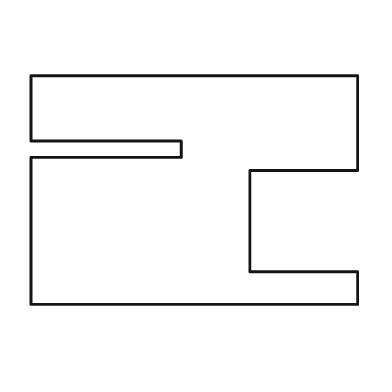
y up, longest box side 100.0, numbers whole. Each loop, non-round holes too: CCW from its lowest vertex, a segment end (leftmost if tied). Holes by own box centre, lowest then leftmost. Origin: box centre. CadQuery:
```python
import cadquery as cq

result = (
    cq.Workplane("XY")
    .moveTo(-50.0, -35.0)
    .lineTo(50.0, -35.0)
    .lineTo(50.0, -25.0)
    .lineTo(17.0, -25.0)
    .lineTo(17.0, 6.0)
    .lineTo(50.0, 6.0)
    .lineTo(50.0, 35.0)
    .lineTo(-50.0, 35.0)
    .lineTo(-50.0, 15.0)
    .lineTo(-4.0, 15.0)
    .lineTo(-4.0, 10.0)
    .lineTo(-50.0, 10.0)
    .close()
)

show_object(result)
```